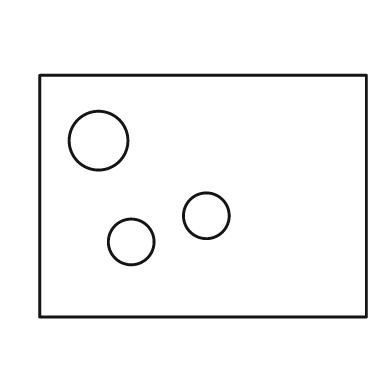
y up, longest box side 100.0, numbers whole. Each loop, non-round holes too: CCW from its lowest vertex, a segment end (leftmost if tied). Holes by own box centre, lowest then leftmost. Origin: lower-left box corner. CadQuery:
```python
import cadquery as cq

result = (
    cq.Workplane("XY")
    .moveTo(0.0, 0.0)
    .lineTo(100.0, 0.0)
    .lineTo(100.0, 74.0)
    .lineTo(0.0, 74.0)
    .close()
    .moveTo(28.0, 23.0)
    .circle(7.0)
    .moveTo(51.0, 31.0)
    .circle(7.0)
    .moveTo(18.0, 54.0)
    .circle(9.0)
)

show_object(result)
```